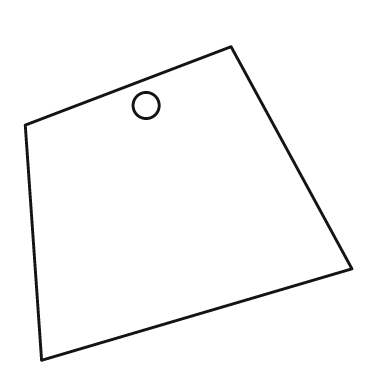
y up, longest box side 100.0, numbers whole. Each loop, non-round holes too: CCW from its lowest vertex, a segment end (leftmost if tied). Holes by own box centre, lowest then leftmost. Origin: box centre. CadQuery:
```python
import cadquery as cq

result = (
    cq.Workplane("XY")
    .moveTo(-45.0, -48.0)
    .lineTo(50.0, -20.0)
    .lineTo(13.0, 48.0)
    .lineTo(-50.0, 24.0)
    .close()
    .moveTo(-13.0, 30.0)
    .circle(4.0)
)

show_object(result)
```